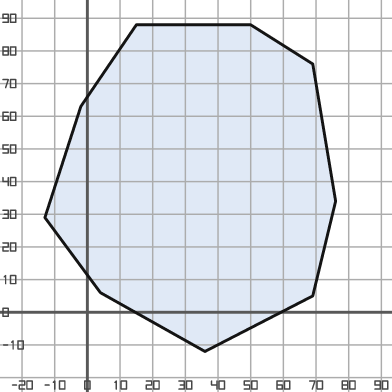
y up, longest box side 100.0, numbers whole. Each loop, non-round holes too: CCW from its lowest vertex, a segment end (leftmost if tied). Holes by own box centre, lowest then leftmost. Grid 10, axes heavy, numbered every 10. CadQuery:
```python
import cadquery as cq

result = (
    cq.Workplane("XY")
    .moveTo(36.0, -12.0)
    .lineTo(69.0, 5.0)
    .lineTo(76.0, 34.0)
    .lineTo(69.0, 76.0)
    .lineTo(50.0, 88.0)
    .lineTo(15.0, 88.0)
    .lineTo(-2.0, 63.0)
    .lineTo(-13.0, 29.0)
    .lineTo(4.0, 6.0)
    .close()
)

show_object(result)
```